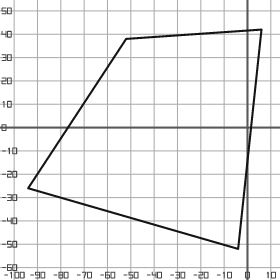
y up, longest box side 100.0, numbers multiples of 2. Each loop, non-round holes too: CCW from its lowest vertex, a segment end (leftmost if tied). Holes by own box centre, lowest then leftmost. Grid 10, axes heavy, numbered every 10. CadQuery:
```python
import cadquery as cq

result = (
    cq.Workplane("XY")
    .moveTo(-4.0, -52.0)
    .lineTo(6.0, 42.0)
    .lineTo(-52.0, 38.0)
    .lineTo(-94.0, -26.0)
    .close()
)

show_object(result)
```